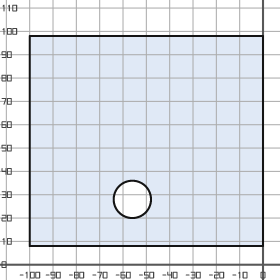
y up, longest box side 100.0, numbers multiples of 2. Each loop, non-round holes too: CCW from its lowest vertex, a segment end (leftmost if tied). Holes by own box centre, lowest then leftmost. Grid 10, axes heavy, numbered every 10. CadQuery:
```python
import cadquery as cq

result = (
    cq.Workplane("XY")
    .moveTo(-100.0, 8.0)
    .lineTo(0.0, 8.0)
    .lineTo(0.0, 98.0)
    .lineTo(-100.0, 98.0)
    .close()
    .moveTo(-56.0, 28.0)
    .circle(8.0)
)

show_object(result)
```